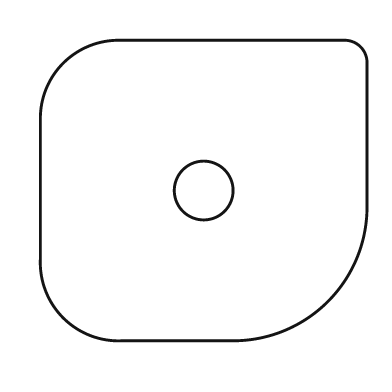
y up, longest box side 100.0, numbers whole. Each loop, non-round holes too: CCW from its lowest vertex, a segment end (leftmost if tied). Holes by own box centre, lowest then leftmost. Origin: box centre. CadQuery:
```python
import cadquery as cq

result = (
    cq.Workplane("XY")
    .moveTo(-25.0, -46.0)
    .lineTo(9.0, -46.0)
    .threePointArc((38.0, -34.0), (50.0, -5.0))
    .lineTo(50.0, 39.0)
    .threePointArc((48.0, 44.0), (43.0, 46.0))
    .lineTo(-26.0, 46.0)
    .threePointArc((-43.0, 39.0), (-50.0, 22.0))
    .lineTo(-50.0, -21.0)
    .threePointArc((-43.0, -39.0), (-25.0, -46.0))
    .close()
    .moveTo(0.0, 0.0)
    .circle(9.0)
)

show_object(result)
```